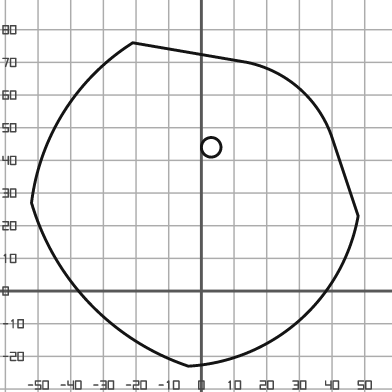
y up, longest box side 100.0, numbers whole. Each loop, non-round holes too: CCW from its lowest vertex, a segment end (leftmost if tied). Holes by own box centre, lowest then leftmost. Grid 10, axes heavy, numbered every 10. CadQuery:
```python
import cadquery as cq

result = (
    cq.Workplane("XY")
    .moveTo(-4.0, -23.0)
    .threePointArc((30.0, -9.0), (48.0, 23.0))
    .lineTo(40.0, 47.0)
    .threePointArc((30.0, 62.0), (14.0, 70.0))
    .lineTo(-21.0, 76.0)
    .threePointArc((-42.0, 55.0), (-52.0, 27.0))
    .threePointArc((-34.0, -4.0), (-4.0, -23.0))
    .close()
    .moveTo(3.0, 44.0)
    .circle(3.0)
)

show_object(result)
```